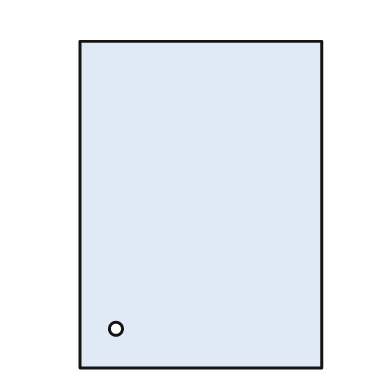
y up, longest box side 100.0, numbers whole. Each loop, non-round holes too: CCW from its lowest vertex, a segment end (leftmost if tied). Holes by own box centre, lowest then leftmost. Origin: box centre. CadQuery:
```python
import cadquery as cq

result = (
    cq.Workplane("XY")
    .moveTo(-37.0, -50.0)
    .lineTo(37.0, -50.0)
    .lineTo(37.0, 50.0)
    .lineTo(-37.0, 50.0)
    .close()
    .moveTo(-26.0, -38.0)
    .circle(2.0)
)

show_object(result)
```